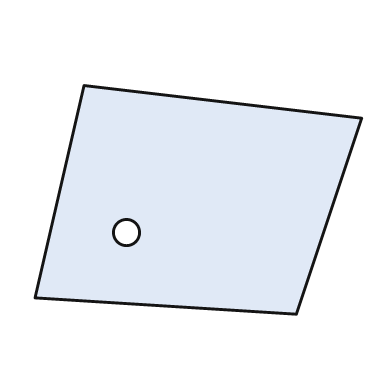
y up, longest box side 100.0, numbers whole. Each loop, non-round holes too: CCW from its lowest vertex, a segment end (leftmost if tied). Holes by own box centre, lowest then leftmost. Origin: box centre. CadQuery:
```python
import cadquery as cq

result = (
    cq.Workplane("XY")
    .moveTo(30.0, -35.0)
    .lineTo(50.0, 25.0)
    .lineTo(-35.0, 35.0)
    .lineTo(-50.0, -30.0)
    .close()
    .moveTo(-22.0, -10.0)
    .circle(4.0)
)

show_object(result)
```